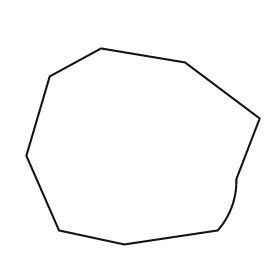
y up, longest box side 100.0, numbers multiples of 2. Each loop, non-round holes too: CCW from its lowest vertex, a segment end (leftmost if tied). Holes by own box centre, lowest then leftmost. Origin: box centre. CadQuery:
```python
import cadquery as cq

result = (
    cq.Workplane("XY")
    .moveTo(-8.0, -42.0)
    .lineTo(32.0, -36.0)
    .threePointArc((38.0, -26.0), (40.0, -14.0))
    .lineTo(50.0, 12.0)
    .lineTo(18.0, 36.0)
    .lineTo(-18.0, 42.0)
    .lineTo(-40.0, 30.0)
    .lineTo(-50.0, -4.0)
    .lineTo(-36.0, -36.0)
    .close()
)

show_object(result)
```